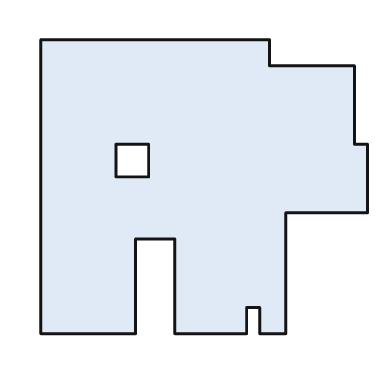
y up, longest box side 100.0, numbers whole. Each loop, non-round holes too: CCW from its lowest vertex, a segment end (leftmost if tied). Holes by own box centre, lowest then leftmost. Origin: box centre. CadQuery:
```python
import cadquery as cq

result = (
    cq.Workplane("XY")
    .moveTo(-50.0, -45.0)
    .lineTo(-21.0, -45.0)
    .lineTo(-21.0, -16.0)
    .lineTo(-9.0, -16.0)
    .lineTo(-9.0, -45.0)
    .lineTo(13.0, -45.0)
    .lineTo(13.0, -37.0)
    .lineTo(17.0, -37.0)
    .lineTo(17.0, -45.0)
    .lineTo(25.0, -45.0)
    .lineTo(25.0, -8.0)
    .lineTo(50.0, -8.0)
    .lineTo(50.0, 13.0)
    .lineTo(46.0, 13.0)
    .lineTo(46.0, 37.0)
    .lineTo(20.0, 37.0)
    .lineTo(20.0, 45.0)
    .lineTo(-50.0, 45.0)
    .close()
    .moveTo(-27.0, 3.0)
    .lineTo(-17.0, 3.0)
    .lineTo(-17.0, 13.0)
    .lineTo(-27.0, 13.0)
    .close()
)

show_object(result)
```